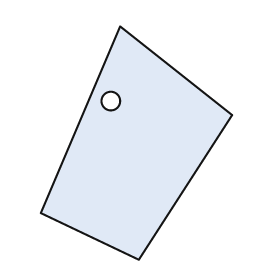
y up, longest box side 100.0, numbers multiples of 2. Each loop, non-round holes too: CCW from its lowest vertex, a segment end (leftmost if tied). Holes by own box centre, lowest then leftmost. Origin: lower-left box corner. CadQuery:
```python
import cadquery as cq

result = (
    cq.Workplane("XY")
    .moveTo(42.0, 0.0)
    .lineTo(82.0, 62.0)
    .lineTo(34.0, 100.0)
    .lineTo(0.0, 20.0)
    .close()
    .moveTo(30.0, 68.0)
    .circle(4.0)
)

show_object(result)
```